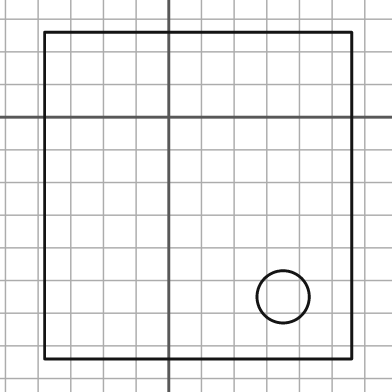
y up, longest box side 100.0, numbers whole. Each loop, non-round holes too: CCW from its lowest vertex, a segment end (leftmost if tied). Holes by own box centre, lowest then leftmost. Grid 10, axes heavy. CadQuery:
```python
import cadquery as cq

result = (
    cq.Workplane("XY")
    .moveTo(-38.0, -74.0)
    .lineTo(56.0, -74.0)
    .lineTo(56.0, 26.0)
    .lineTo(-38.0, 26.0)
    .close()
    .moveTo(35.0, -55.0)
    .circle(8.0)
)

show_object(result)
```